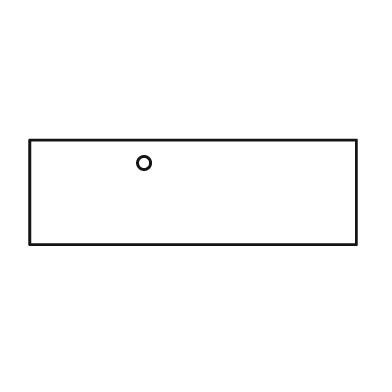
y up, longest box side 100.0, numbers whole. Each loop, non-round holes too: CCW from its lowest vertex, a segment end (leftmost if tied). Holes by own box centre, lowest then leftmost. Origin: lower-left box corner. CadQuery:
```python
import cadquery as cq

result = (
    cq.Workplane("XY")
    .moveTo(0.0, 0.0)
    .lineTo(100.0, 0.0)
    .lineTo(100.0, 32.0)
    .lineTo(0.0, 32.0)
    .close()
    .moveTo(35.0, 25.0)
    .circle(2.0)
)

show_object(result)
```